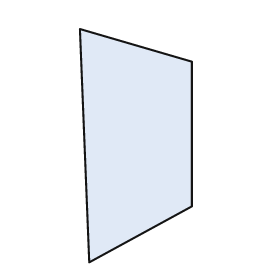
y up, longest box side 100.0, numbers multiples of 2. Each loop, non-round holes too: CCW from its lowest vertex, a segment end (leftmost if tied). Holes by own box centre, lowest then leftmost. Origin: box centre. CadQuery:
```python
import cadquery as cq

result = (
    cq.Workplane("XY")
    .moveTo(-20.0, -50.0)
    .lineTo(24.0, -26.0)
    .lineTo(24.0, 36.0)
    .lineTo(-24.0, 50.0)
    .close()
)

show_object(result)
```